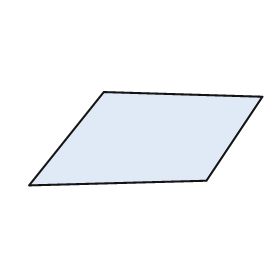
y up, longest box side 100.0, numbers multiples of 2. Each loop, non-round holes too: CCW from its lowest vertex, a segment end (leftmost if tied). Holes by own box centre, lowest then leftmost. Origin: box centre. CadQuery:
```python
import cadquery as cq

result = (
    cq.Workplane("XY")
    .moveTo(-50.0, -20.0)
    .lineTo(26.0, -18.0)
    .lineTo(50.0, 18.0)
    .lineTo(-18.0, 20.0)
    .close()
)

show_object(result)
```